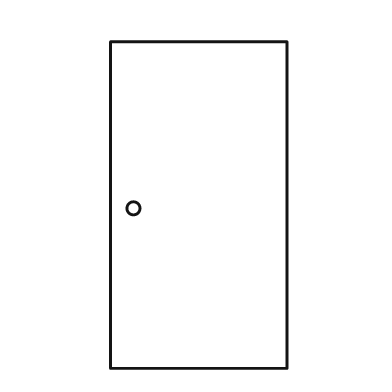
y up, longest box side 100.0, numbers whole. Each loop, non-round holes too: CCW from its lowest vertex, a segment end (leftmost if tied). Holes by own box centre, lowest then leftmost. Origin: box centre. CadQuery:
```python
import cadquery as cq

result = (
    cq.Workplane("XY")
    .moveTo(-27.0, -50.0)
    .lineTo(27.0, -50.0)
    .lineTo(27.0, 50.0)
    .lineTo(-27.0, 50.0)
    .close()
    .moveTo(-20.0, -1.0)
    .circle(2.0)
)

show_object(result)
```